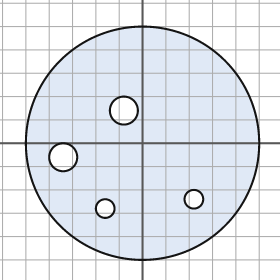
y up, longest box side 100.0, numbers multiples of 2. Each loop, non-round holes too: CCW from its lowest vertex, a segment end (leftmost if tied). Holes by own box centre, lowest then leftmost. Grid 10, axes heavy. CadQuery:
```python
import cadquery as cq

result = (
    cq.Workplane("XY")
    .moveTo(0.0, 0.0)
    .circle(50.0)
    .moveTo(-16.0, -28.0)
    .circle(4.0)
    .moveTo(22.0, -24.0)
    .circle(4.0)
    .moveTo(-34.0, -6.0)
    .circle(6.0)
    .moveTo(-8.0, 14.0)
    .circle(6.0)
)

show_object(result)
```